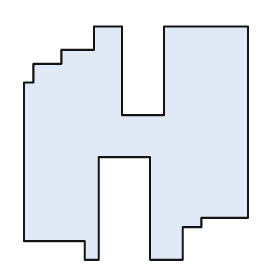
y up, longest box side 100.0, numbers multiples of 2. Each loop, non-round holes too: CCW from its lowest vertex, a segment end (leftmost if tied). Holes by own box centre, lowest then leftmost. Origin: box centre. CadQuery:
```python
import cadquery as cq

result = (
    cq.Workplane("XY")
    .moveTo(-22.0, -50.0)
    .lineTo(-16.0, -50.0)
    .lineTo(-16.0, -6.0)
    .lineTo(6.0, -6.0)
    .lineTo(6.0, -50.0)
    .lineTo(20.0, -50.0)
    .lineTo(20.0, -36.0)
    .lineTo(28.0, -36.0)
    .lineTo(28.0, -32.0)
    .lineTo(48.0, -32.0)
    .lineTo(48.0, 50.0)
    .lineTo(12.0, 50.0)
    .lineTo(12.0, 12.0)
    .lineTo(-6.0, 12.0)
    .lineTo(-6.0, 50.0)
    .lineTo(-18.0, 50.0)
    .lineTo(-18.0, 40.0)
    .lineTo(-32.0, 40.0)
    .lineTo(-32.0, 34.0)
    .lineTo(-44.0, 34.0)
    .lineTo(-44.0, 26.0)
    .lineTo(-48.0, 26.0)
    .lineTo(-48.0, -42.0)
    .lineTo(-22.0, -42.0)
    .close()
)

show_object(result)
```